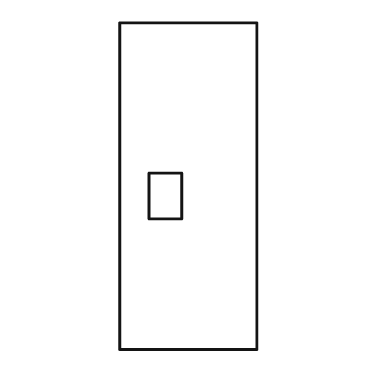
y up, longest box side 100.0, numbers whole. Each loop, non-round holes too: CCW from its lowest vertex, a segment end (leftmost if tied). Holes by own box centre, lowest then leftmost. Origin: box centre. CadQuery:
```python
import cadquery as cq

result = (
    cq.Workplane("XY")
    .moveTo(-21.0, -50.0)
    .lineTo(21.0, -50.0)
    .lineTo(21.0, 50.0)
    .lineTo(-21.0, 50.0)
    .close()
    .moveTo(-12.0, -10.0)
    .lineTo(-2.0, -10.0)
    .lineTo(-2.0, 4.0)
    .lineTo(-12.0, 4.0)
    .close()
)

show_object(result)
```